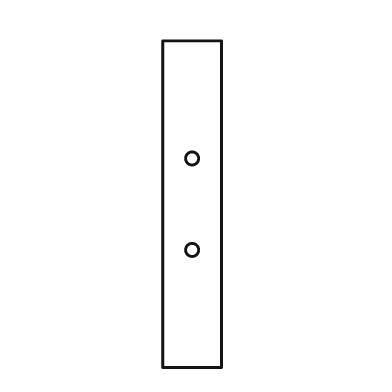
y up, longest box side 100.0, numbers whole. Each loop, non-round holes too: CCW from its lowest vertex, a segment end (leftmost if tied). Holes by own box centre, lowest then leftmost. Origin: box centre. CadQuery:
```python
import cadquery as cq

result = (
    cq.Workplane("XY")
    .moveTo(-9.0, -50.0)
    .lineTo(9.0, -50.0)
    .lineTo(9.0, 50.0)
    .lineTo(-9.0, 50.0)
    .close()
    .moveTo(0.0, -14.0)
    .circle(2.0)
    .moveTo(0.0, 14.0)
    .circle(2.0)
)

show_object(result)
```